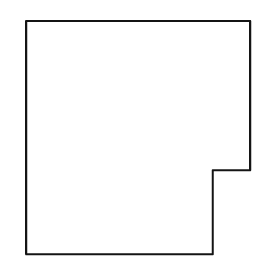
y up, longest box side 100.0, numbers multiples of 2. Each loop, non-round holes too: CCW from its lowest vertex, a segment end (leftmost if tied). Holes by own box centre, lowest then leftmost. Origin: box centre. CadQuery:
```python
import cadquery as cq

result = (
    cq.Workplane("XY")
    .moveTo(-48.0, -50.0)
    .lineTo(32.0, -50.0)
    .lineTo(32.0, -14.0)
    .lineTo(48.0, -14.0)
    .lineTo(48.0, 50.0)
    .lineTo(-48.0, 50.0)
    .close()
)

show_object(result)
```